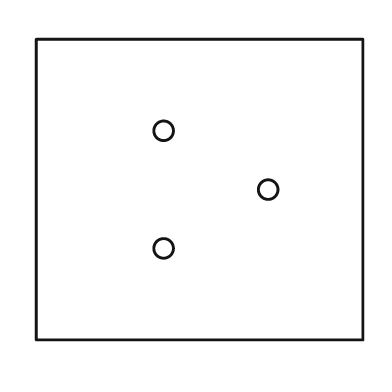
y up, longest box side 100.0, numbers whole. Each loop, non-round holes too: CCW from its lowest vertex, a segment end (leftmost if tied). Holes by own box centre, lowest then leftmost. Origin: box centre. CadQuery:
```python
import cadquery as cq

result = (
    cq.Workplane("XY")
    .moveTo(-50.0, -46.0)
    .lineTo(50.0, -46.0)
    .lineTo(50.0, 46.0)
    .lineTo(-50.0, 46.0)
    .close()
    .moveTo(-11.0, -18.0)
    .circle(3.0)
    .moveTo(21.0, 0.0)
    .circle(3.0)
    .moveTo(-11.0, 18.0)
    .circle(3.0)
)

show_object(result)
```